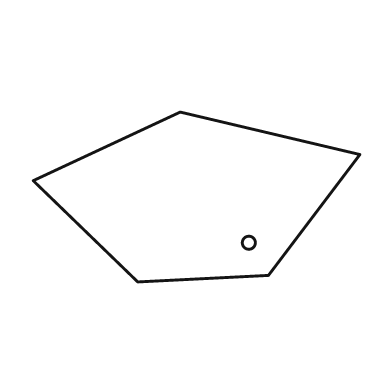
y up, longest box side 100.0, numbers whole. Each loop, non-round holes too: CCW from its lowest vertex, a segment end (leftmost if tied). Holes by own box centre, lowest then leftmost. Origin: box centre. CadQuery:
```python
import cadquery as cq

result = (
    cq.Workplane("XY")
    .moveTo(-18.0, -26.0)
    .lineTo(22.0, -24.0)
    .lineTo(50.0, 13.0)
    .lineTo(-5.0, 26.0)
    .lineTo(-50.0, 5.0)
    .close()
    .moveTo(16.0, -14.0)
    .circle(2.0)
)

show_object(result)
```